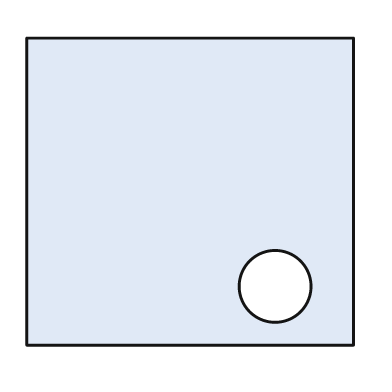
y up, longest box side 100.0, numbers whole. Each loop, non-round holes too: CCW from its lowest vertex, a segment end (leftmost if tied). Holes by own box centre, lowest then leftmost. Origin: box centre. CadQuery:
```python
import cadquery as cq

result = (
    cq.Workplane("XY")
    .moveTo(-50.0, -47.0)
    .lineTo(50.0, -47.0)
    .lineTo(50.0, 47.0)
    .lineTo(-50.0, 47.0)
    .close()
    .moveTo(26.0, -29.0)
    .circle(11.0)
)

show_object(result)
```